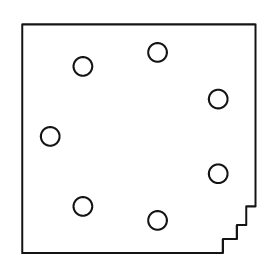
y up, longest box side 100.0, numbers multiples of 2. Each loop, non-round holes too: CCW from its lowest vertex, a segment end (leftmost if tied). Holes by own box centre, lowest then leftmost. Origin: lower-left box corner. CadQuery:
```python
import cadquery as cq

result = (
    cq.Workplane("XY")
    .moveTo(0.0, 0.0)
    .lineTo(86.0, 0.0)
    .lineTo(86.0, 6.0)
    .lineTo(92.0, 6.0)
    .lineTo(92.0, 12.0)
    .lineTo(96.0, 12.0)
    .lineTo(96.0, 20.0)
    .lineTo(100.0, 20.0)
    .lineTo(100.0, 98.0)
    .lineTo(0.0, 98.0)
    .close()
    .moveTo(58.0, 14.0)
    .circle(4.0)
    .moveTo(26.0, 20.0)
    .circle(4.0)
    .moveTo(84.0, 34.0)
    .circle(4.0)
    .moveTo(12.0, 50.0)
    .circle(4.0)
    .moveTo(84.0, 66.0)
    .circle(4.0)
    .moveTo(26.0, 80.0)
    .circle(4.0)
    .moveTo(58.0, 86.0)
    .circle(4.0)
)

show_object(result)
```